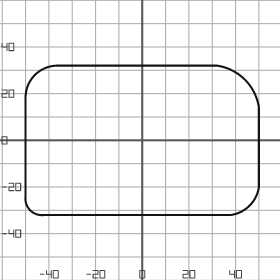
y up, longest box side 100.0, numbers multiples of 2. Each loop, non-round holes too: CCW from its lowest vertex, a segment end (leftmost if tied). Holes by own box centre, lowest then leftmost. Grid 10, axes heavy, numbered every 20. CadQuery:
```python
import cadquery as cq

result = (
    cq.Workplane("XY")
    .moveTo(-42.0, -32.0)
    .lineTo(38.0, -32.0)
    .threePointArc((46.0, -28.0), (50.0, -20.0))
    .lineTo(50.0, 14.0)
    .threePointArc((44.0, 26.0), (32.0, 32.0))
    .lineTo(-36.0, 32.0)
    .threePointArc((-46.0, 28.0), (-50.0, 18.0))
    .lineTo(-50.0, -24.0)
    .threePointArc((-48.0, -30.0), (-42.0, -32.0))
    .close()
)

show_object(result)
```